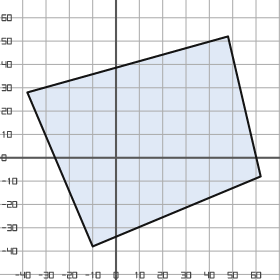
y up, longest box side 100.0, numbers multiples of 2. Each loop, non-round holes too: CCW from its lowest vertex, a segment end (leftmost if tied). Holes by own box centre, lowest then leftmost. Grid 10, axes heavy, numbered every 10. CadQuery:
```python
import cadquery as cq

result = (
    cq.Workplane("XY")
    .moveTo(-10.0, -38.0)
    .lineTo(62.0, -8.0)
    .lineTo(48.0, 52.0)
    .lineTo(-38.0, 28.0)
    .close()
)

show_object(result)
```